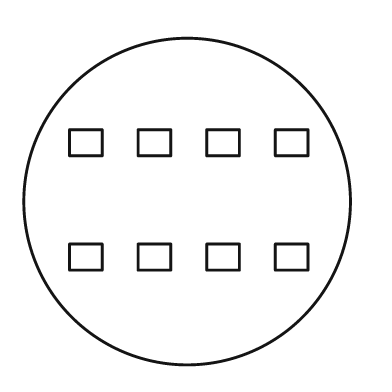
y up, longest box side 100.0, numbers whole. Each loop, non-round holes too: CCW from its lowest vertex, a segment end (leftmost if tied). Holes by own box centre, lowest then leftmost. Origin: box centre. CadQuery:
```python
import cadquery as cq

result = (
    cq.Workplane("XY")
    .moveTo(0.0, 0.0)
    .circle(50.0)
    .moveTo(-36.0, -21.0)
    .lineTo(-26.0, -21.0)
    .lineTo(-26.0, -13.0)
    .lineTo(-36.0, -13.0)
    .close()
    .moveTo(-15.0, -21.0)
    .lineTo(-5.0, -21.0)
    .lineTo(-5.0, -13.0)
    .lineTo(-15.0, -13.0)
    .close()
    .moveTo(6.0, -21.0)
    .lineTo(16.0, -21.0)
    .lineTo(16.0, -13.0)
    .lineTo(6.0, -13.0)
    .close()
    .moveTo(27.0, -21.0)
    .lineTo(37.0, -21.0)
    .lineTo(37.0, -13.0)
    .lineTo(27.0, -13.0)
    .close()
    .moveTo(-36.0, 14.0)
    .lineTo(-26.0, 14.0)
    .lineTo(-26.0, 22.0)
    .lineTo(-36.0, 22.0)
    .close()
    .moveTo(-15.0, 14.0)
    .lineTo(-5.0, 14.0)
    .lineTo(-5.0, 22.0)
    .lineTo(-15.0, 22.0)
    .close()
    .moveTo(6.0, 14.0)
    .lineTo(16.0, 14.0)
    .lineTo(16.0, 22.0)
    .lineTo(6.0, 22.0)
    .close()
    .moveTo(27.0, 14.0)
    .lineTo(37.0, 14.0)
    .lineTo(37.0, 22.0)
    .lineTo(27.0, 22.0)
    .close()
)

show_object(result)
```